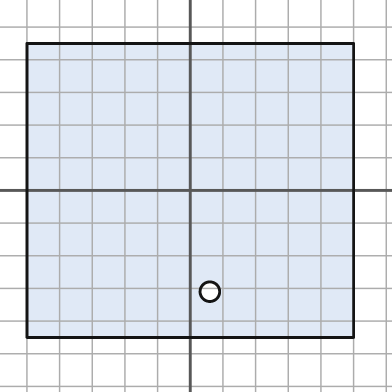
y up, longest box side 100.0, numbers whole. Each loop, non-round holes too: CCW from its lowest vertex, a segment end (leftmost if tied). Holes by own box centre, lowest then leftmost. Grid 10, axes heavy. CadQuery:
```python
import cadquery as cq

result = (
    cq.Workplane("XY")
    .moveTo(-50.0, -45.0)
    .lineTo(50.0, -45.0)
    .lineTo(50.0, 45.0)
    .lineTo(-50.0, 45.0)
    .close()
    .moveTo(6.0, -31.0)
    .circle(3.0)
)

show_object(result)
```